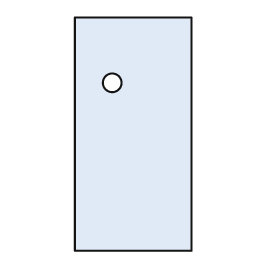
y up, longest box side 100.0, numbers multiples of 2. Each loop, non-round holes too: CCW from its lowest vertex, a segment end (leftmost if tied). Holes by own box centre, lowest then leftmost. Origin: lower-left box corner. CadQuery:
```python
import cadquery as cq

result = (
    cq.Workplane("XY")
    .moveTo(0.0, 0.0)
    .lineTo(50.0, 0.0)
    .lineTo(50.0, 100.0)
    .lineTo(0.0, 100.0)
    .close()
    .moveTo(16.0, 72.0)
    .circle(4.0)
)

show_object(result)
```